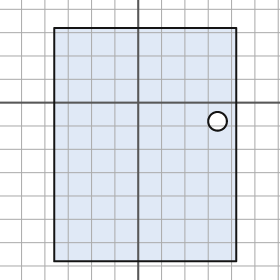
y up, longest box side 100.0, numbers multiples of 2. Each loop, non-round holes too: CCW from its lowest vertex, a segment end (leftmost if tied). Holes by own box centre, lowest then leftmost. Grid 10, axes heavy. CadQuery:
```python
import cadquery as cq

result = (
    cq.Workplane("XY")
    .moveTo(-36.0, -68.0)
    .lineTo(42.0, -68.0)
    .lineTo(42.0, 32.0)
    .lineTo(-36.0, 32.0)
    .close()
    .moveTo(34.0, -8.0)
    .circle(4.0)
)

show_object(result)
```